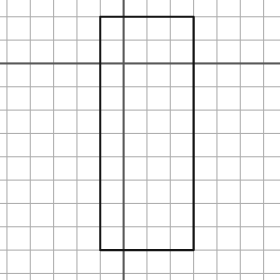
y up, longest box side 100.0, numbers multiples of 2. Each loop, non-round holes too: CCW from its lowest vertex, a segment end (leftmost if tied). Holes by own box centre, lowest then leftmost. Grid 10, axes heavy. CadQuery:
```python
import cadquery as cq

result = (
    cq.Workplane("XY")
    .moveTo(-10.0, -80.0)
    .lineTo(30.0, -80.0)
    .lineTo(30.0, 20.0)
    .lineTo(-10.0, 20.0)
    .close()
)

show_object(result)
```